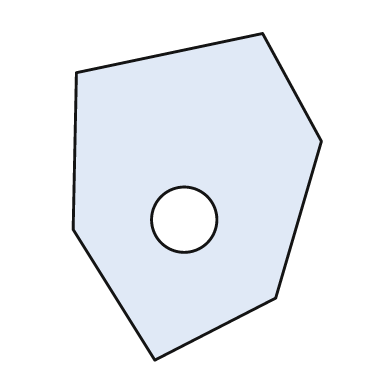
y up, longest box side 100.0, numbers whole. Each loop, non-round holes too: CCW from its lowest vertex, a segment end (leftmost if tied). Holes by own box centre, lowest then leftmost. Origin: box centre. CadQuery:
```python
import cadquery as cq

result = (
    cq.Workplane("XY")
    .moveTo(-13.0, -50.0)
    .lineTo(24.0, -31.0)
    .lineTo(38.0, 17.0)
    .lineTo(20.0, 50.0)
    .lineTo(-37.0, 38.0)
    .lineTo(-38.0, -10.0)
    .close()
    .moveTo(-4.0, -7.0)
    .circle(10.0)
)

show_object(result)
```